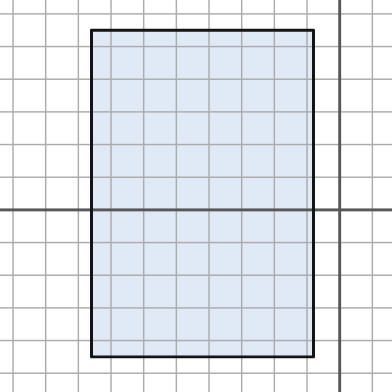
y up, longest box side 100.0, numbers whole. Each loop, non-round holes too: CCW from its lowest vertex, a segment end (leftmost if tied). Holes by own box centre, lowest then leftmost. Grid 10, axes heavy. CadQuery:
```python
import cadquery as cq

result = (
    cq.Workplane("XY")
    .moveTo(-76.0, -45.0)
    .lineTo(-8.0, -45.0)
    .lineTo(-8.0, 55.0)
    .lineTo(-76.0, 55.0)
    .close()
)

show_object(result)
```